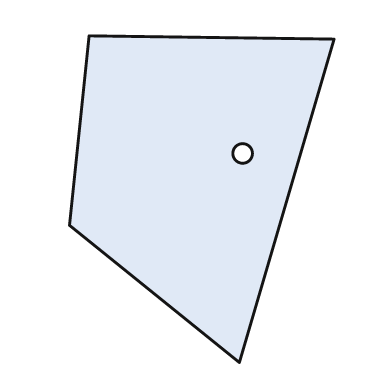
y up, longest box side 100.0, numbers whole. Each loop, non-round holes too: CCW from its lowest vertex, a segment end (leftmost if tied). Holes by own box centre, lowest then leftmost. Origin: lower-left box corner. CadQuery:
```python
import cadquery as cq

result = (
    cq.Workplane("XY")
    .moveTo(52.0, 0.0)
    .lineTo(81.0, 99.0)
    .lineTo(6.0, 100.0)
    .lineTo(0.0, 42.0)
    .close()
    .moveTo(53.0, 64.0)
    .circle(3.0)
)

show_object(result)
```